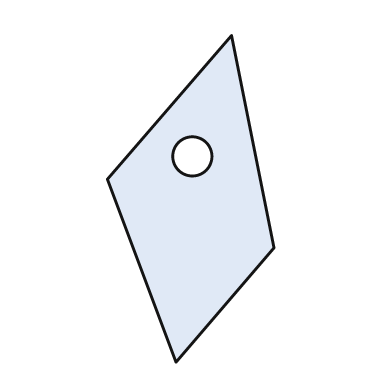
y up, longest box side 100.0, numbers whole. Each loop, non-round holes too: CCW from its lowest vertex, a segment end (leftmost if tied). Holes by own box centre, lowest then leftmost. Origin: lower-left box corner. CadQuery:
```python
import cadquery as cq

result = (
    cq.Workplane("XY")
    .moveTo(21.0, 0.0)
    .lineTo(51.0, 35.0)
    .lineTo(38.0, 100.0)
    .lineTo(0.0, 56.0)
    .close()
    .moveTo(26.0, 63.0)
    .circle(6.0)
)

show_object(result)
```